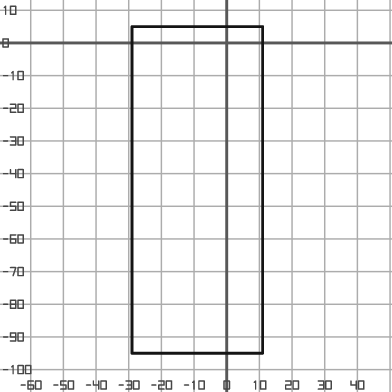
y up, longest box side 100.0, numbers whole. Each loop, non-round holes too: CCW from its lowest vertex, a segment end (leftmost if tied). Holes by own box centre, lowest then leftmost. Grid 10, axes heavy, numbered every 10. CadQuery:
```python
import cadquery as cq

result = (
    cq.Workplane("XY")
    .moveTo(-29.0, -95.0)
    .lineTo(11.0, -95.0)
    .lineTo(11.0, 5.0)
    .lineTo(-29.0, 5.0)
    .close()
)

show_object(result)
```